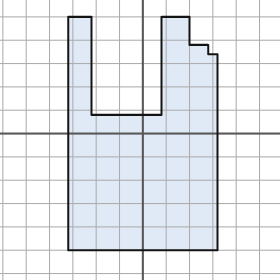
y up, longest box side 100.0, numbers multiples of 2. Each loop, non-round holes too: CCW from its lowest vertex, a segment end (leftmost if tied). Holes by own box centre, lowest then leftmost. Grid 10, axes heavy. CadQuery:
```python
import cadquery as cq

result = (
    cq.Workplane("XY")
    .moveTo(-32.0, -50.0)
    .lineTo(32.0, -50.0)
    .lineTo(32.0, 34.0)
    .lineTo(28.0, 34.0)
    .lineTo(28.0, 38.0)
    .lineTo(20.0, 38.0)
    .lineTo(20.0, 50.0)
    .lineTo(8.0, 50.0)
    .lineTo(8.0, 8.0)
    .lineTo(-22.0, 8.0)
    .lineTo(-22.0, 50.0)
    .lineTo(-32.0, 50.0)
    .close()
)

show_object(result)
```